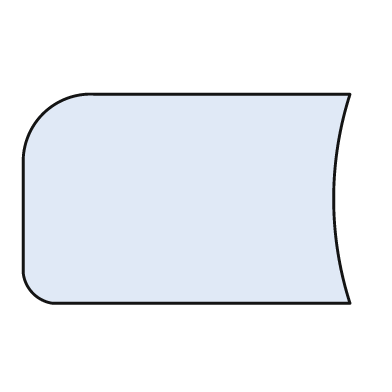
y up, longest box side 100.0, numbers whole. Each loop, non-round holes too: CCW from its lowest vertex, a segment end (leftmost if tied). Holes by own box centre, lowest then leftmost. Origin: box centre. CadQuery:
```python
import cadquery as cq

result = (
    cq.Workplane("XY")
    .moveTo(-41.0, -32.0)
    .lineTo(50.0, -32.0)
    .threePointArc((45.0, 0.0), (50.0, 32.0))
    .lineTo(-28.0, 32.0)
    .threePointArc((-44.0, 26.0), (-50.0, 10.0))
    .lineTo(-50.0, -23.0)
    .threePointArc((-47.0, -29.0), (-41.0, -32.0))
    .close()
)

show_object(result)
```